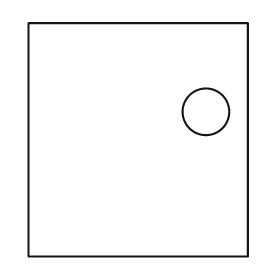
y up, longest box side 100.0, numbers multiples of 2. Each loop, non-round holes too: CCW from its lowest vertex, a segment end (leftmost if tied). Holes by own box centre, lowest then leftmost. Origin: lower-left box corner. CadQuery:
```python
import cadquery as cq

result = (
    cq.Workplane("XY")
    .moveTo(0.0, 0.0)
    .lineTo(94.0, 0.0)
    .lineTo(94.0, 100.0)
    .lineTo(0.0, 100.0)
    .close()
    .moveTo(76.0, 62.0)
    .circle(10.0)
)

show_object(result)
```